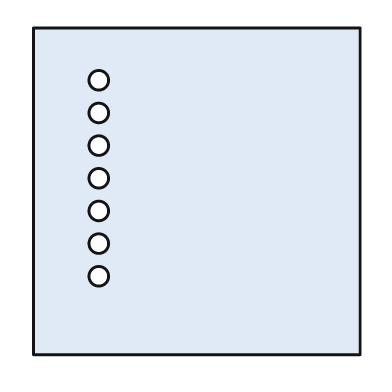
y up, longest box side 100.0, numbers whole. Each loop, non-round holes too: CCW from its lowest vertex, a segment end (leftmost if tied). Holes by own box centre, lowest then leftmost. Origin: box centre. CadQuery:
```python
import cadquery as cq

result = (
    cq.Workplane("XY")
    .moveTo(-50.0, -50.0)
    .lineTo(50.0, -50.0)
    .lineTo(50.0, 50.0)
    .lineTo(-50.0, 50.0)
    .close()
    .moveTo(-30.0, -26.0)
    .circle(3.0)
    .moveTo(-30.0, -16.0)
    .circle(3.0)
    .moveTo(-30.0, -6.0)
    .circle(3.0)
    .moveTo(-30.0, 4.0)
    .circle(3.0)
    .moveTo(-30.0, 14.0)
    .circle(3.0)
    .moveTo(-30.0, 24.0)
    .circle(3.0)
    .moveTo(-30.0, 34.0)
    .circle(3.0)
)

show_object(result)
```